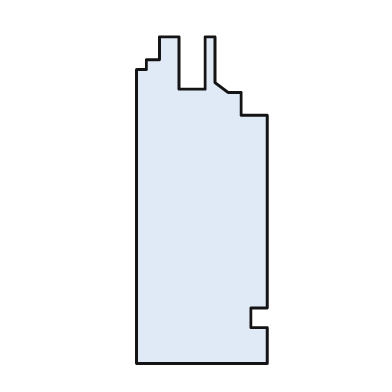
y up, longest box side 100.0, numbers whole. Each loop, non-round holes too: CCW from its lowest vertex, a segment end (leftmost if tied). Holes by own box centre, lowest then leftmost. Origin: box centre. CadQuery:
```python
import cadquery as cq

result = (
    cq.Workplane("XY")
    .moveTo(-20.0, -50.0)
    .lineTo(20.0, -50.0)
    .lineTo(20.0, -39.0)
    .lineTo(15.0, -39.0)
    .lineTo(15.0, -33.0)
    .lineTo(20.0, -33.0)
    .lineTo(20.0, 26.0)
    .lineTo(12.0, 26.0)
    .lineTo(12.0, 33.0)
    .lineTo(8.0, 33.0)
    .lineTo(4.0, 36.0)
    .lineTo(4.0, 50.0)
    .lineTo(1.0, 50.0)
    .lineTo(1.0, 34.0)
    .lineTo(-7.0, 34.0)
    .lineTo(-7.0, 50.0)
    .lineTo(-13.0, 50.0)
    .lineTo(-13.0, 43.0)
    .lineTo(-17.0, 43.0)
    .lineTo(-17.0, 40.0)
    .lineTo(-20.0, 40.0)
    .close()
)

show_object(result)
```